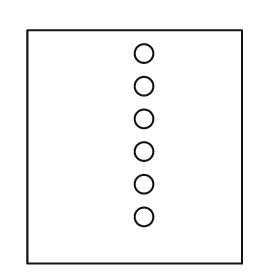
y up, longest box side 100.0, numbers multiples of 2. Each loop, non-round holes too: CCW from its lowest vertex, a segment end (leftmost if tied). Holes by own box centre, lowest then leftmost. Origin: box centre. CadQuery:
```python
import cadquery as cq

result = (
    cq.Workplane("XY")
    .moveTo(-46.0, -50.0)
    .lineTo(46.0, -50.0)
    .lineTo(46.0, 50.0)
    .lineTo(-46.0, 50.0)
    .close()
    .moveTo(4.0, -30.0)
    .circle(4.0)
    .moveTo(4.0, -16.0)
    .circle(4.0)
    .moveTo(4.0, -2.0)
    .circle(4.0)
    .moveTo(4.0, 12.0)
    .circle(4.0)
    .moveTo(4.0, 26.0)
    .circle(4.0)
    .moveTo(4.0, 40.0)
    .circle(4.0)
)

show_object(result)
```